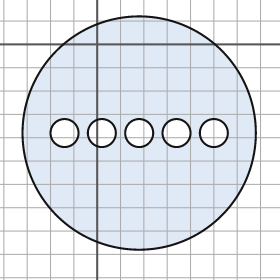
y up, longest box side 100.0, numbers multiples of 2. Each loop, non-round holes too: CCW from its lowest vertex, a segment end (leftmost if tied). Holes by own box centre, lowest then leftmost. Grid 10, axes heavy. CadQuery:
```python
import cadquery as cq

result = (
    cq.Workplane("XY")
    .moveTo(18.0, -38.0)
    .circle(50.0)
    .moveTo(-14.0, -38.0)
    .circle(6.0)
    .moveTo(2.0, -38.0)
    .circle(6.0)
    .moveTo(18.0, -38.0)
    .circle(6.0)
    .moveTo(34.0, -38.0)
    .circle(6.0)
    .moveTo(50.0, -38.0)
    .circle(6.0)
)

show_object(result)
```